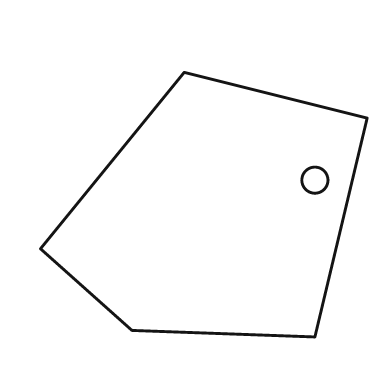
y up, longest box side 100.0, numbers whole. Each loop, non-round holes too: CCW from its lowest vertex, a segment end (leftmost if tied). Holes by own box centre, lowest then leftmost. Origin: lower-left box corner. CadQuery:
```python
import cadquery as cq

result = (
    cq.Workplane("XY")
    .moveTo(84.0, 0.0)
    .lineTo(100.0, 67.0)
    .lineTo(44.0, 81.0)
    .lineTo(0.0, 27.0)
    .lineTo(28.0, 2.0)
    .close()
    .moveTo(84.0, 48.0)
    .circle(4.0)
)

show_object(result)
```